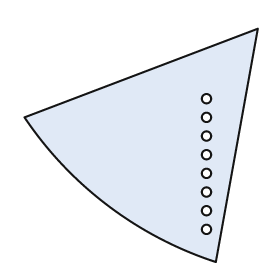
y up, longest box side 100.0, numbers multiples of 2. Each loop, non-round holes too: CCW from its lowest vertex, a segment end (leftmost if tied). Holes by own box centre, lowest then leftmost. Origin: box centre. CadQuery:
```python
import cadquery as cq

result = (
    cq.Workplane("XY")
    .moveTo(32.0, -50.0)
    .lineTo(50.0, 50.0)
    .lineTo(-50.0, 12.0)
    .threePointArc((-14.0, -26.0), (32.0, -50.0))
    .close()
    .moveTo(28.0, -36.0)
    .circle(2.0)
    .moveTo(28.0, -28.0)
    .circle(2.0)
    .moveTo(28.0, -20.0)
    .circle(2.0)
    .moveTo(28.0, -12.0)
    .circle(2.0)
    .moveTo(28.0, -4.0)
    .circle(2.0)
    .moveTo(28.0, 4.0)
    .circle(2.0)
    .moveTo(28.0, 12.0)
    .circle(2.0)
    .moveTo(28.0, 20.0)
    .circle(2.0)
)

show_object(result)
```